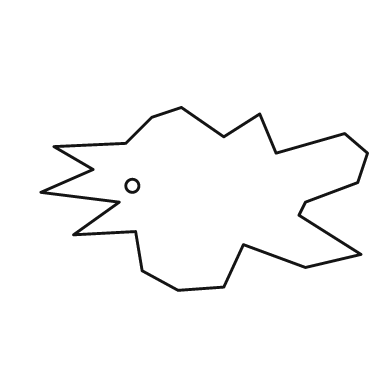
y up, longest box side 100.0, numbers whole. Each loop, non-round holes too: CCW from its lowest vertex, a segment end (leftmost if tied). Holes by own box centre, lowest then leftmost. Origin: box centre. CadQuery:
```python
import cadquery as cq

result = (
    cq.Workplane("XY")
    .moveTo(-8.0, -28.0)
    .lineTo(6.0, -27.0)
    .lineTo(12.0, -14.0)
    .lineTo(31.0, -21.0)
    .lineTo(48.0, -17.0)
    .lineTo(29.0, -5.0)
    .lineTo(31.0, -1.0)
    .lineTo(47.0, 5.0)
    .lineTo(50.0, 14.0)
    .lineTo(43.0, 20.0)
    .lineTo(22.0, 14.0)
    .lineTo(17.0, 26.0)
    .lineTo(6.0, 19.0)
    .lineTo(-7.0, 28.0)
    .lineTo(-16.0, 25.0)
    .lineTo(-24.0, 17.0)
    .lineTo(-46.0, 16.0)
    .lineTo(-34.0, 9.0)
    .lineTo(-50.0, 2.0)
    .lineTo(-26.0, -1.0)
    .lineTo(-40.0, -11.0)
    .lineTo(-21.0, -10.0)
    .lineTo(-19.0, -22.0)
    .close()
    .moveTo(-22.0, 4.0)
    .circle(2.0)
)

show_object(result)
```